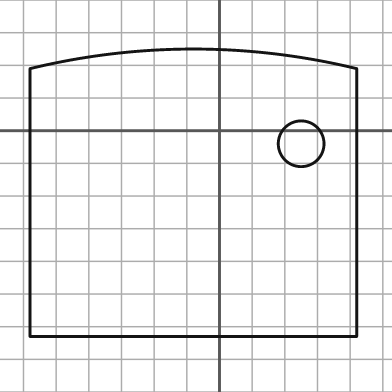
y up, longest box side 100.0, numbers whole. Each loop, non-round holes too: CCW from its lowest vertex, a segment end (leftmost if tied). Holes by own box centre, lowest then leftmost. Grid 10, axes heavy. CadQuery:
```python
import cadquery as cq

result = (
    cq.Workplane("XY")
    .moveTo(-58.0, -63.0)
    .lineTo(42.0, -63.0)
    .lineTo(42.0, 19.0)
    .threePointArc((-8.0, 25.0), (-58.0, 19.0))
    .close()
    .moveTo(25.0, -4.0)
    .circle(7.0)
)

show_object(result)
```